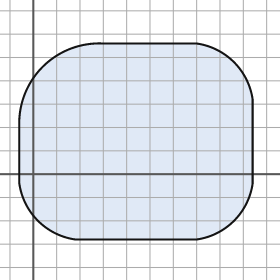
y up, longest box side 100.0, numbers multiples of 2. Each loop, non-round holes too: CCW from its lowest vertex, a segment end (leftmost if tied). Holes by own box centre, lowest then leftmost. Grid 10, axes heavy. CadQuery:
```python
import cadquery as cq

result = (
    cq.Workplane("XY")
    .moveTo(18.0, -28.0)
    .lineTo(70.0, -28.0)
    .threePointArc((86.0, -20.0), (94.0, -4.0))
    .lineTo(94.0, 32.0)
    .threePointArc((86.0, 48.0), (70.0, 56.0))
    .lineTo(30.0, 56.0)
    .threePointArc((4.0, 46.0), (-6.0, 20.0))
    .lineTo(-6.0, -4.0)
    .threePointArc((2.0, -20.0), (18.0, -28.0))
    .close()
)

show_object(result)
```